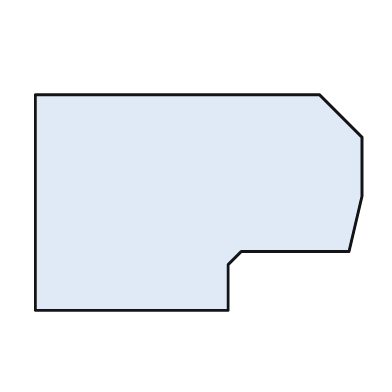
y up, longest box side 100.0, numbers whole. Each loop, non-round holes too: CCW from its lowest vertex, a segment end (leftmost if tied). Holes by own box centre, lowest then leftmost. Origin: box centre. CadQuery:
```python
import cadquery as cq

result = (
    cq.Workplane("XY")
    .moveTo(-50.0, -33.0)
    .lineTo(9.0, -33.0)
    .lineTo(9.0, -19.0)
    .lineTo(13.0, -15.0)
    .lineTo(46.0, -15.0)
    .lineTo(50.0, 2.0)
    .lineTo(50.0, 20.0)
    .lineTo(37.0, 33.0)
    .lineTo(-50.0, 33.0)
    .close()
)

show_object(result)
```